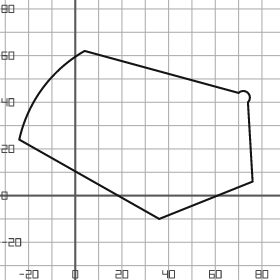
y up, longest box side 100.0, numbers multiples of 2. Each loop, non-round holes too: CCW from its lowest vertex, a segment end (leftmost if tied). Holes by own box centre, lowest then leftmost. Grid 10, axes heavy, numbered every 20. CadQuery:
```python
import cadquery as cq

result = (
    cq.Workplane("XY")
    .moveTo(36.0, -10.0)
    .lineTo(76.0, 6.0)
    .lineTo(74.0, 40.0)
    .threePointArc((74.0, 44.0), (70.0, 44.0))
    .lineTo(4.0, 62.0)
    .threePointArc((-14.0, 46.0), (-24.0, 24.0))
    .close()
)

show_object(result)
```